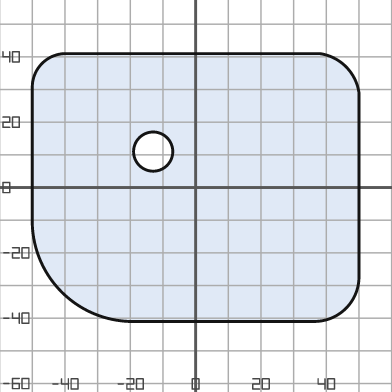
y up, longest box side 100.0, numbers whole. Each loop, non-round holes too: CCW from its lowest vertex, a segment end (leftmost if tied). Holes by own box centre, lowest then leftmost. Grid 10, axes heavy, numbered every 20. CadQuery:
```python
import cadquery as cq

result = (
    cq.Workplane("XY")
    .moveTo(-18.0, -41.0)
    .lineTo(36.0, -41.0)
    .threePointArc((46.0, -37.0), (50.0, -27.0))
    .lineTo(50.0, 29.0)
    .threePointArc((46.0, 37.0), (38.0, 41.0))
    .lineTo(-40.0, 41.0)
    .threePointArc((-47.0, 38.0), (-50.0, 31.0))
    .lineTo(-50.0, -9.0)
    .threePointArc((-41.0, -32.0), (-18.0, -41.0))
    .close()
    .moveTo(-13.0, 11.0)
    .circle(6.0)
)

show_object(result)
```